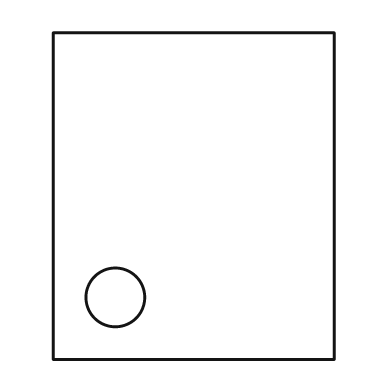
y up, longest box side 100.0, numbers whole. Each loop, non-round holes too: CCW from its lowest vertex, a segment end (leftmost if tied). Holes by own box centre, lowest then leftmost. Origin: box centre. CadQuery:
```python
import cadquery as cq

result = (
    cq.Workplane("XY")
    .moveTo(-43.0, -50.0)
    .lineTo(43.0, -50.0)
    .lineTo(43.0, 50.0)
    .lineTo(-43.0, 50.0)
    .close()
    .moveTo(-24.0, -31.0)
    .circle(9.0)
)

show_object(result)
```